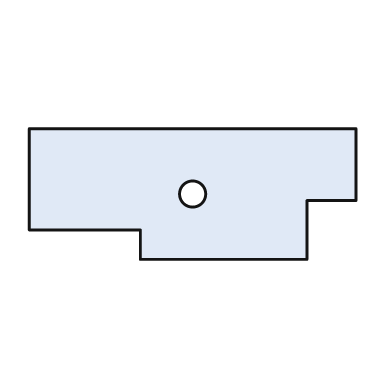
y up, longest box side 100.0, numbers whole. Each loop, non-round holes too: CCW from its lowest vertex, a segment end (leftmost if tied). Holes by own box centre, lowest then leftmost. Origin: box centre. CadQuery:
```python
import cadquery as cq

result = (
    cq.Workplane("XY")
    .moveTo(-16.0, -20.0)
    .lineTo(35.0, -20.0)
    .lineTo(35.0, -2.0)
    .lineTo(50.0, -2.0)
    .lineTo(50.0, 20.0)
    .lineTo(-50.0, 20.0)
    .lineTo(-50.0, -11.0)
    .lineTo(-16.0, -11.0)
    .close()
    .moveTo(0.0, 0.0)
    .circle(4.0)
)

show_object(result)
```